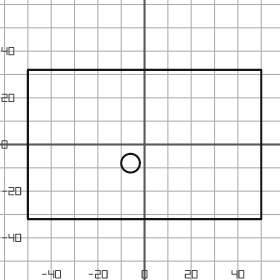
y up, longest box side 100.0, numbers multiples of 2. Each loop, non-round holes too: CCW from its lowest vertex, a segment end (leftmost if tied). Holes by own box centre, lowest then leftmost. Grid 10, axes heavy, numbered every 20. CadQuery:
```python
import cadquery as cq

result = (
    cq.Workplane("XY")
    .moveTo(-50.0, -32.0)
    .lineTo(50.0, -32.0)
    .lineTo(50.0, 32.0)
    .lineTo(-50.0, 32.0)
    .close()
    .moveTo(-6.0, -8.0)
    .circle(4.0)
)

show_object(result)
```